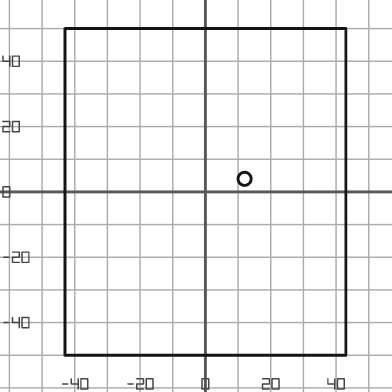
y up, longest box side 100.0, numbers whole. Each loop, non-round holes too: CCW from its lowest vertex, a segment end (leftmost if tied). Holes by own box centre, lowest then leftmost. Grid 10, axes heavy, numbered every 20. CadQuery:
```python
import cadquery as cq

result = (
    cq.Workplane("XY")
    .moveTo(-43.0, -50.0)
    .lineTo(43.0, -50.0)
    .lineTo(43.0, 50.0)
    .lineTo(-43.0, 50.0)
    .close()
    .moveTo(12.0, 4.0)
    .circle(2.0)
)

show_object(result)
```